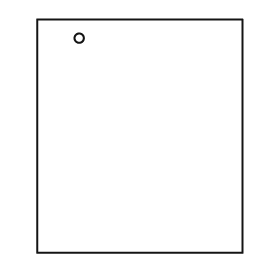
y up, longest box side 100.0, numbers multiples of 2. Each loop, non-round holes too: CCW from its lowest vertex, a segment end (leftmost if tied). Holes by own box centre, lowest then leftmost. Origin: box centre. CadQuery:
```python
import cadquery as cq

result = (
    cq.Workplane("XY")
    .moveTo(-44.0, -50.0)
    .lineTo(44.0, -50.0)
    .lineTo(44.0, 50.0)
    .lineTo(-44.0, 50.0)
    .close()
    .moveTo(-26.0, 42.0)
    .circle(2.0)
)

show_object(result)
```